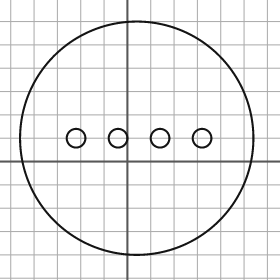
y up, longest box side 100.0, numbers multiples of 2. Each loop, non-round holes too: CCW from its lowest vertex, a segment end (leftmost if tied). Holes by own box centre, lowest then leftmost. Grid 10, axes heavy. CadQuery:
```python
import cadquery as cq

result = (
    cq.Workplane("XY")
    .moveTo(4.0, 10.0)
    .circle(50.0)
    .moveTo(-22.0, 10.0)
    .circle(4.0)
    .moveTo(-4.0, 10.0)
    .circle(4.0)
    .moveTo(14.0, 10.0)
    .circle(4.0)
    .moveTo(32.0, 10.0)
    .circle(4.0)
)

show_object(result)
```